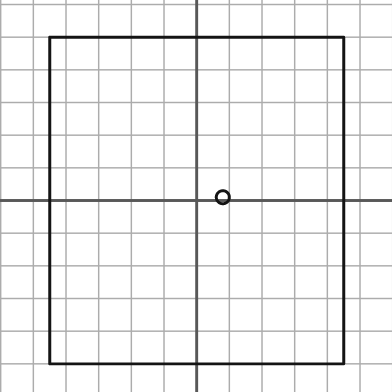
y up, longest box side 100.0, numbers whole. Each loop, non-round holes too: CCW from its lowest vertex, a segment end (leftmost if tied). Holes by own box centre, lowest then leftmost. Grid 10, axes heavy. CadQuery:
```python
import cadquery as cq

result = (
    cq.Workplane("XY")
    .moveTo(-45.0, -50.0)
    .lineTo(45.0, -50.0)
    .lineTo(45.0, 50.0)
    .lineTo(-45.0, 50.0)
    .close()
    .moveTo(8.0, 1.0)
    .circle(2.0)
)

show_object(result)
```